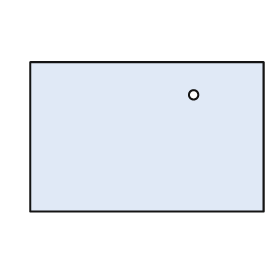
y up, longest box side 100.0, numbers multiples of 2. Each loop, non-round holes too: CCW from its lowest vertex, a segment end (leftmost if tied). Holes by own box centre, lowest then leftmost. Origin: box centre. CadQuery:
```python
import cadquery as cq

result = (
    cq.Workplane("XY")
    .moveTo(-50.0, -32.0)
    .lineTo(50.0, -32.0)
    .lineTo(50.0, 32.0)
    .lineTo(-50.0, 32.0)
    .close()
    .moveTo(20.0, 18.0)
    .circle(2.0)
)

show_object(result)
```